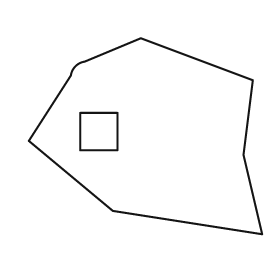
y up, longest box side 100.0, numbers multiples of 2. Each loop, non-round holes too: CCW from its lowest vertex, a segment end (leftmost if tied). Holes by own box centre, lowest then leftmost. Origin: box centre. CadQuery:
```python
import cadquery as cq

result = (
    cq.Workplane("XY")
    .moveTo(50.0, -42.0)
    .lineTo(42.0, -8.0)
    .lineTo(46.0, 24.0)
    .lineTo(-2.0, 42.0)
    .lineTo(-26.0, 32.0)
    .threePointArc((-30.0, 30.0), (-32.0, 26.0))
    .lineTo(-50.0, -2.0)
    .lineTo(-14.0, -32.0)
    .close()
    .moveTo(-28.0, -6.0)
    .lineTo(-12.0, -6.0)
    .lineTo(-12.0, 10.0)
    .lineTo(-28.0, 10.0)
    .close()
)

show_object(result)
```